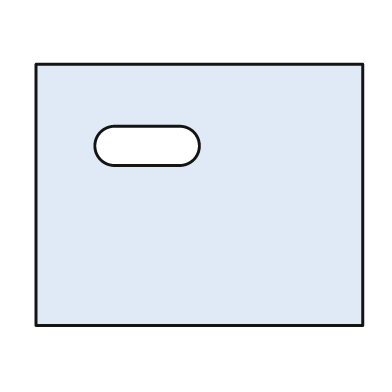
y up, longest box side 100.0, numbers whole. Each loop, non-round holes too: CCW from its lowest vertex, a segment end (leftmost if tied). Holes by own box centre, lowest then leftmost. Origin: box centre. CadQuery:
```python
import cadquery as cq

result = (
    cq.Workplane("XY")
    .moveTo(-50.0, -40.0)
    .lineTo(50.0, -40.0)
    .lineTo(50.0, 40.0)
    .lineTo(-50.0, 40.0)
    .close()
    .moveTo(-26.0, 9.0)
    .lineTo(-6.0, 9.0)
    .threePointArc((0.0, 15.0), (-6.0, 21.0))
    .lineTo(-26.0, 21.0)
    .threePointArc((-32.0, 15.0), (-26.0, 9.0))
    .close()
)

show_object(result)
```